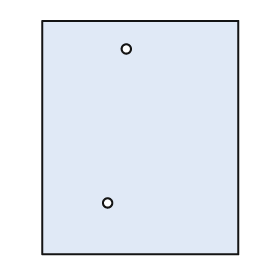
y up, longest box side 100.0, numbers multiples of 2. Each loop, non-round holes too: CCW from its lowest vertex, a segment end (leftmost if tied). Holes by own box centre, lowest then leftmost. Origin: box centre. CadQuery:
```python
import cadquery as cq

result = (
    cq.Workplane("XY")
    .moveTo(-42.0, -50.0)
    .lineTo(42.0, -50.0)
    .lineTo(42.0, 50.0)
    .lineTo(-42.0, 50.0)
    .close()
    .moveTo(-14.0, -28.0)
    .circle(2.0)
    .moveTo(-6.0, 38.0)
    .circle(2.0)
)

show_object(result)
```